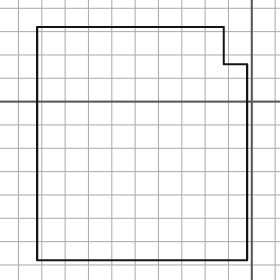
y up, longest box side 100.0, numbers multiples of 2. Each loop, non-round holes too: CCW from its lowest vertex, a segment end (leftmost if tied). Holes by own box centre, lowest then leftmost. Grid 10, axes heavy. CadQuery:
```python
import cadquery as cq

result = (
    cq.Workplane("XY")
    .moveTo(-92.0, -68.0)
    .lineTo(-2.0, -68.0)
    .lineTo(-2.0, 16.0)
    .lineTo(-12.0, 16.0)
    .lineTo(-12.0, 32.0)
    .lineTo(-92.0, 32.0)
    .close()
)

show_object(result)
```